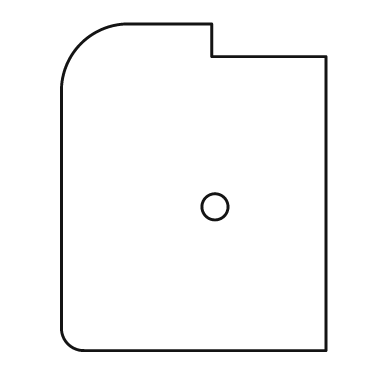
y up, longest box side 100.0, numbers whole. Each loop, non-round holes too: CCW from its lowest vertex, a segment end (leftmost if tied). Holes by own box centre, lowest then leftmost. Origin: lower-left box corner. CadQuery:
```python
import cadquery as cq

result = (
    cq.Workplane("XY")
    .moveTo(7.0, 0.0)
    .lineTo(81.0, 0.0)
    .lineTo(81.0, 90.0)
    .lineTo(46.0, 90.0)
    .lineTo(46.0, 100.0)
    .lineTo(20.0, 100.0)
    .threePointArc((6.0, 94.0), (0.0, 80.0))
    .lineTo(0.0, 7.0)
    .threePointArc((2.0, 2.0), (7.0, 0.0))
    .close()
    .moveTo(47.0, 44.0)
    .circle(4.0)
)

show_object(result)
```